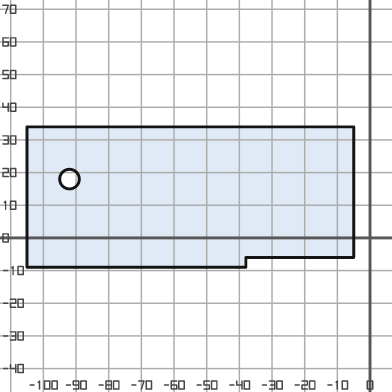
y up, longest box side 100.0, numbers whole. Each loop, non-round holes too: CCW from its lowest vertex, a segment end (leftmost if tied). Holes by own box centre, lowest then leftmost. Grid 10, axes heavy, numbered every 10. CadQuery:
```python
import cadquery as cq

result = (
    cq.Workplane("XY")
    .moveTo(-105.0, -9.0)
    .lineTo(-38.0, -9.0)
    .lineTo(-38.0, -6.0)
    .lineTo(-5.0, -6.0)
    .lineTo(-5.0, 34.0)
    .lineTo(-105.0, 34.0)
    .close()
    .moveTo(-92.0, 18.0)
    .circle(3.0)
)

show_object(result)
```